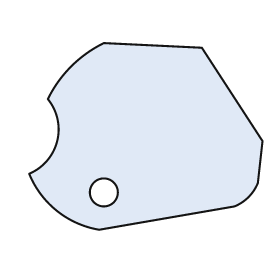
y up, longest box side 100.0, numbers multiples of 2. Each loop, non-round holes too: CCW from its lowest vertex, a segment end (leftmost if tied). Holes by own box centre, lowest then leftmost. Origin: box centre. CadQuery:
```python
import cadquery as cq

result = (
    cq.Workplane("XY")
    .moveTo(-20.0, -40.0)
    .lineTo(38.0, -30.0)
    .threePointArc((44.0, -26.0), (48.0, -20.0))
    .lineTo(50.0, -2.0)
    .lineTo(24.0, 38.0)
    .lineTo(-18.0, 40.0)
    .threePointArc((-32.0, 30.0), (-42.0, 16.0))
    .threePointArc((-38.0, -2.0), (-50.0, -16.0))
    .threePointArc((-38.0, -32.0), (-20.0, -40.0))
    .close()
    .moveTo(-18.0, -24.0)
    .circle(6.0)
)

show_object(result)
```